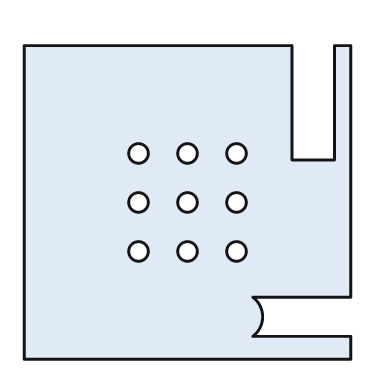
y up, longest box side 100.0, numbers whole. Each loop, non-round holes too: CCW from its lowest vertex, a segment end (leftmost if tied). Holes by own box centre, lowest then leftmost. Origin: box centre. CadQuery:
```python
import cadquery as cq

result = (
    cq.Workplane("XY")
    .moveTo(-50.0, -48.0)
    .lineTo(50.0, -48.0)
    .lineTo(50.0, -41.0)
    .lineTo(20.0, -41.0)
    .threePointArc((23.0, -35.0), (20.0, -29.0))
    .lineTo(50.0, -29.0)
    .lineTo(50.0, 48.0)
    .lineTo(45.0, 48.0)
    .lineTo(45.0, 13.0)
    .lineTo(32.0, 13.0)
    .lineTo(32.0, 48.0)
    .lineTo(-50.0, 48.0)
    .close()
    .moveTo(-15.0, -15.0)
    .circle(3.0)
    .moveTo(0.0, -15.0)
    .circle(3.0)
    .moveTo(15.0, -15.0)
    .circle(3.0)
    .moveTo(-15.0, 0.0)
    .circle(3.0)
    .moveTo(0.0, 0.0)
    .circle(3.0)
    .moveTo(15.0, 0.0)
    .circle(3.0)
    .moveTo(-15.0, 15.0)
    .circle(3.0)
    .moveTo(0.0, 15.0)
    .circle(3.0)
    .moveTo(15.0, 15.0)
    .circle(3.0)
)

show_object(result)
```